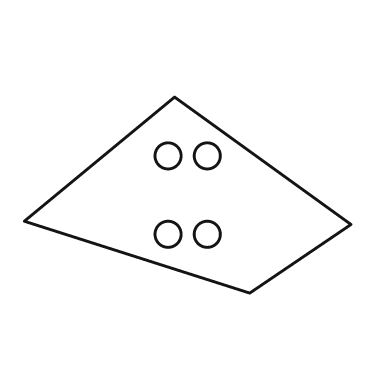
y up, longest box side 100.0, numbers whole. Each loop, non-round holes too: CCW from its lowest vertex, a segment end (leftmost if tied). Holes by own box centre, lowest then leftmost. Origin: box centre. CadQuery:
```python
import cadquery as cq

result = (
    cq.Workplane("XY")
    .moveTo(19.0, -30.0)
    .lineTo(50.0, -9.0)
    .lineTo(-4.0, 30.0)
    .lineTo(-50.0, -8.0)
    .close()
    .moveTo(-6.0, -12.0)
    .circle(4.0)
    .moveTo(6.0, -12.0)
    .circle(4.0)
    .moveTo(-6.0, 12.0)
    .circle(4.0)
    .moveTo(6.0, 12.0)
    .circle(4.0)
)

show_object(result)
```